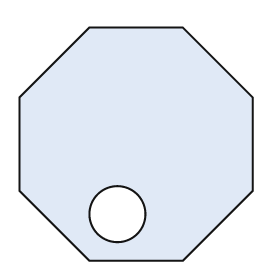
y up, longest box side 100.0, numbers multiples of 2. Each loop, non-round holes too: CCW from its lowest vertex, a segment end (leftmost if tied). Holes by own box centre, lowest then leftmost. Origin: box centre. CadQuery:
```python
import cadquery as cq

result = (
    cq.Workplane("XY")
    .moveTo(-20.0, -50.0)
    .lineTo(20.0, -50.0)
    .lineTo(50.0, -20.0)
    .lineTo(50.0, 20.0)
    .lineTo(20.0, 50.0)
    .lineTo(-20.0, 50.0)
    .lineTo(-50.0, 20.0)
    .lineTo(-50.0, -20.0)
    .close()
    .moveTo(-8.0, -30.0)
    .circle(12.0)
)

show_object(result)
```